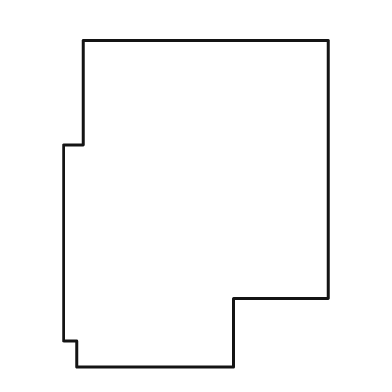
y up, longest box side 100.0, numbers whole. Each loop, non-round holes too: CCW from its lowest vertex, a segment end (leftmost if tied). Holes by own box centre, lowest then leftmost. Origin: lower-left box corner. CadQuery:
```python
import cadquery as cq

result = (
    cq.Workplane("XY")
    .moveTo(4.0, 0.0)
    .lineTo(52.0, 0.0)
    .lineTo(52.0, 21.0)
    .lineTo(81.0, 21.0)
    .lineTo(81.0, 100.0)
    .lineTo(6.0, 100.0)
    .lineTo(6.0, 68.0)
    .lineTo(0.0, 68.0)
    .lineTo(0.0, 8.0)
    .lineTo(4.0, 8.0)
    .close()
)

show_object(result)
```